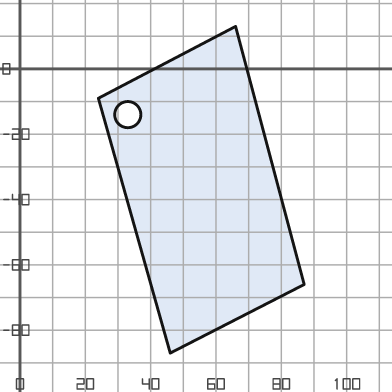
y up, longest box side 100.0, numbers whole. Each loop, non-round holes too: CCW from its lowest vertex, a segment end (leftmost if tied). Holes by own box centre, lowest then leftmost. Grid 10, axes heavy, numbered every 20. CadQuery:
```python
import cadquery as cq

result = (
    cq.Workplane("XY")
    .moveTo(46.0, -87.0)
    .lineTo(87.0, -66.0)
    .lineTo(66.0, 13.0)
    .lineTo(24.0, -9.0)
    .close()
    .moveTo(33.0, -14.0)
    .circle(4.0)
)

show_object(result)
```